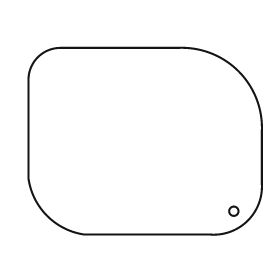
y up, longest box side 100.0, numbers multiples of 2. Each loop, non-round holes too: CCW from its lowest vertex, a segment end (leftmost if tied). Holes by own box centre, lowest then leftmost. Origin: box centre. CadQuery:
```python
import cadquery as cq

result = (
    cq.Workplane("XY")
    .moveTo(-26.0, -40.0)
    .lineTo(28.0, -40.0)
    .threePointArc((44.0, -34.0), (50.0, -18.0))
    .lineTo(50.0, 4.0)
    .threePointArc((40.0, 30.0), (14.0, 40.0))
    .lineTo(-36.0, 40.0)
    .threePointArc((-46.0, 36.0), (-50.0, 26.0))
    .lineTo(-50.0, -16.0)
    .threePointArc((-42.0, -32.0), (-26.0, -40.0))
    .close()
    .moveTo(38.0, -30.0)
    .circle(2.0)
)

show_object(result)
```